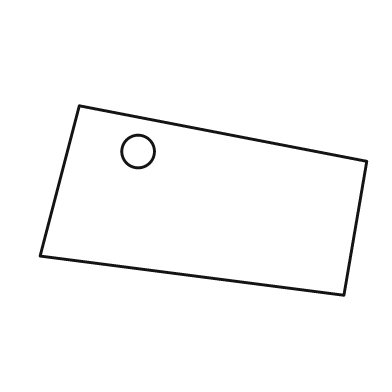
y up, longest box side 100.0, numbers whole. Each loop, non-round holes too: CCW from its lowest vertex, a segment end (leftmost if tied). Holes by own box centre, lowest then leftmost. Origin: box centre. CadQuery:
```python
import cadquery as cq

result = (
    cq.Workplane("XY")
    .moveTo(43.0, -29.0)
    .lineTo(50.0, 12.0)
    .lineTo(-38.0, 29.0)
    .lineTo(-50.0, -17.0)
    .close()
    .moveTo(-20.0, 15.0)
    .circle(5.0)
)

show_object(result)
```